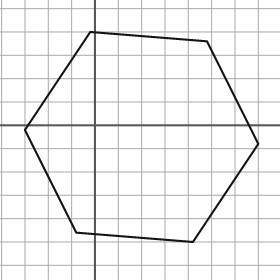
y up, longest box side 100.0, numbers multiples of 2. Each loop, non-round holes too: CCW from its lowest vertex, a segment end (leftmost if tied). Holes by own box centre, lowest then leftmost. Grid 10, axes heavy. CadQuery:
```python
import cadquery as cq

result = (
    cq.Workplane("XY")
    .moveTo(42.0, -50.0)
    .lineTo(70.0, -8.0)
    .lineTo(48.0, 36.0)
    .lineTo(-2.0, 40.0)
    .lineTo(-30.0, -2.0)
    .lineTo(-8.0, -46.0)
    .close()
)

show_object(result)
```